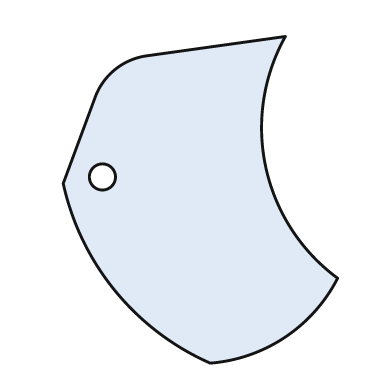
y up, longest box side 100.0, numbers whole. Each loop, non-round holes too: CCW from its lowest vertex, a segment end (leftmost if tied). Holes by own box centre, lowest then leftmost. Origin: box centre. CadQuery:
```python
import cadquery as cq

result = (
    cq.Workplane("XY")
    .moveTo(3.0, -50.0)
    .threePointArc((26.0, -42.0), (42.0, -24.0))
    .threePointArc((20.0, 10.0), (26.0, 50.0))
    .lineTo(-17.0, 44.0)
    .threePointArc((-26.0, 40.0), (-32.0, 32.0))
    .lineTo(-42.0, 5.0)
    .threePointArc((-26.0, -28.0), (3.0, -50.0))
    .close()
    .moveTo(-30.0, 7.0)
    .circle(4.0)
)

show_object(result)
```